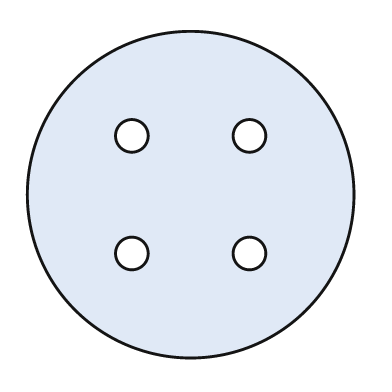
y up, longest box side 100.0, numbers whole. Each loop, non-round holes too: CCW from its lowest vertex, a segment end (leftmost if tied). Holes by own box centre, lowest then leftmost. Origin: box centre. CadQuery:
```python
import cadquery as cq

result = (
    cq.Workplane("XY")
    .moveTo(0.0, 0.0)
    .circle(50.0)
    .moveTo(-18.0, -18.0)
    .circle(5.0)
    .moveTo(18.0, -18.0)
    .circle(5.0)
    .moveTo(-18.0, 18.0)
    .circle(5.0)
    .moveTo(18.0, 18.0)
    .circle(5.0)
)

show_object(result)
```